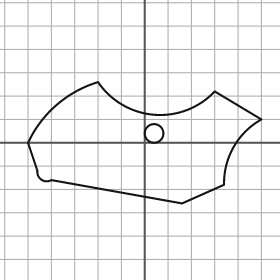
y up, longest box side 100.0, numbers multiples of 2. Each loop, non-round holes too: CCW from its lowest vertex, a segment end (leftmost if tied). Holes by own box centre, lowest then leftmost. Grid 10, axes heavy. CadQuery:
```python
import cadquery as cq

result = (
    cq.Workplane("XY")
    .moveTo(16.0, -26.0)
    .lineTo(34.0, -18.0)
    .threePointArc((38.0, -2.0), (50.0, 10.0))
    .lineTo(30.0, 22.0)
    .threePointArc((4.0, 12.0), (-20.0, 26.0))
    .threePointArc((-38.0, 16.0), (-50.0, 0.0))
    .lineTo(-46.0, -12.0)
    .threePointArc((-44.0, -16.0), (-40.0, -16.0))
    .close()
    .moveTo(4.0, 4.0)
    .circle(4.0)
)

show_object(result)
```